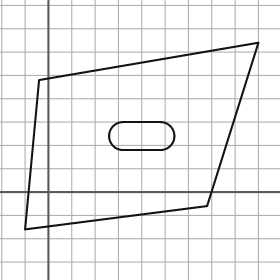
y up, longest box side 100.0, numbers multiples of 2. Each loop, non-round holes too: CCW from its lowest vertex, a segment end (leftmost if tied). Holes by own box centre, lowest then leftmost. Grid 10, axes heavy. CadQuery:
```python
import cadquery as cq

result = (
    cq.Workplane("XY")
    .moveTo(-10.0, -16.0)
    .lineTo(68.0, -6.0)
    .lineTo(90.0, 64.0)
    .lineTo(-4.0, 48.0)
    .close()
    .moveTo(32.0, 18.0)
    .lineTo(48.0, 18.0)
    .threePointArc((54.0, 24.0), (48.0, 30.0))
    .lineTo(32.0, 30.0)
    .threePointArc((26.0, 24.0), (32.0, 18.0))
    .close()
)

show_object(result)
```